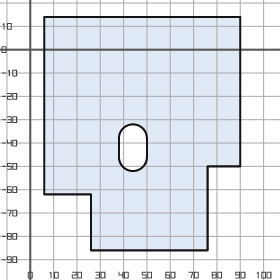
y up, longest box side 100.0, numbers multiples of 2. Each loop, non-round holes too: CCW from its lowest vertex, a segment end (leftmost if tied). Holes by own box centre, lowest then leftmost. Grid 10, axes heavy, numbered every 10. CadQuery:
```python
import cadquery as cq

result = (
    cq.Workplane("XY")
    .moveTo(26.0, -86.0)
    .lineTo(76.0, -86.0)
    .lineTo(76.0, -50.0)
    .lineTo(90.0, -50.0)
    .lineTo(90.0, 14.0)
    .lineTo(6.0, 14.0)
    .lineTo(6.0, -62.0)
    .lineTo(26.0, -62.0)
    .close()
    .moveTo(38.0, -46.0)
    .threePointArc((44.0, -52.0), (50.0, -46.0))
    .lineTo(50.0, -38.0)
    .threePointArc((44.0, -32.0), (38.0, -38.0))
    .close()
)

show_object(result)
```